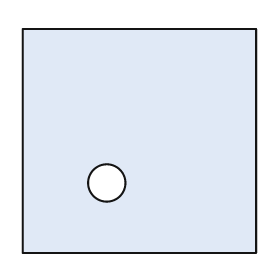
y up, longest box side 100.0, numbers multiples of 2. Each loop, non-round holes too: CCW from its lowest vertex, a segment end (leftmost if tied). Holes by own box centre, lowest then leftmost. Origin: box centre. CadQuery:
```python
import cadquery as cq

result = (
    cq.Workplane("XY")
    .moveTo(-50.0, -48.0)
    .lineTo(50.0, -48.0)
    .lineTo(50.0, 48.0)
    .lineTo(-50.0, 48.0)
    .close()
    .moveTo(-14.0, -18.0)
    .circle(8.0)
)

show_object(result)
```